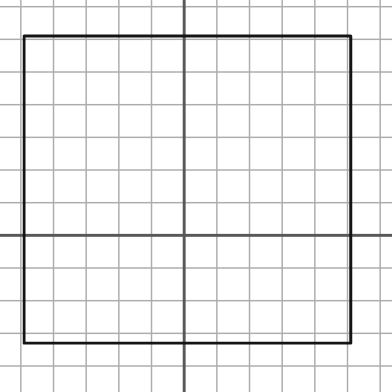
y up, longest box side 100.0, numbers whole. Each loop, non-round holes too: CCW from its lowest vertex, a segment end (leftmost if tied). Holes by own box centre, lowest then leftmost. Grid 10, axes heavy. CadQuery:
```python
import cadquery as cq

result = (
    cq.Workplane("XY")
    .moveTo(-49.0, -33.0)
    .lineTo(51.0, -33.0)
    .lineTo(51.0, 61.0)
    .lineTo(-49.0, 61.0)
    .close()
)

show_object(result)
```